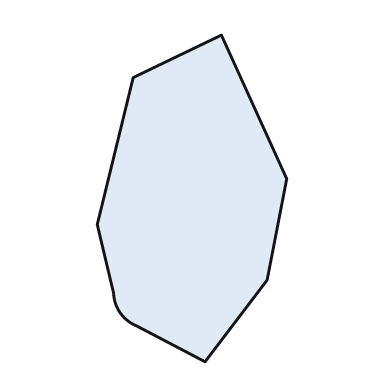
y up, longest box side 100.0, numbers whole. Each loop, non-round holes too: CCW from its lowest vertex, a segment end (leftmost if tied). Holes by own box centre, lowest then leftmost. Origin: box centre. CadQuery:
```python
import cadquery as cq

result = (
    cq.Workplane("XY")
    .moveTo(4.0, -50.0)
    .lineTo(23.0, -25.0)
    .lineTo(29.0, 6.0)
    .lineTo(9.0, 50.0)
    .lineTo(-18.0, 37.0)
    .lineTo(-29.0, -8.0)
    .lineTo(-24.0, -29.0)
    .threePointArc((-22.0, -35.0), (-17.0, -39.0))
    .close()
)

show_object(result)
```